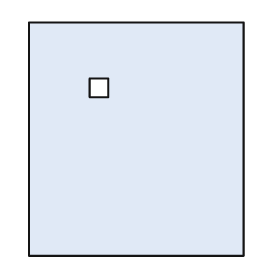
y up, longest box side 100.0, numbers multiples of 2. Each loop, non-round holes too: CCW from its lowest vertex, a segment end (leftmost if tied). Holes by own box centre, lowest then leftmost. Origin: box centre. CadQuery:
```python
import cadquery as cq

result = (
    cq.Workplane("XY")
    .moveTo(-46.0, -50.0)
    .lineTo(46.0, -50.0)
    .lineTo(46.0, 50.0)
    .lineTo(-46.0, 50.0)
    .close()
    .moveTo(-20.0, 18.0)
    .lineTo(-12.0, 18.0)
    .lineTo(-12.0, 26.0)
    .lineTo(-20.0, 26.0)
    .close()
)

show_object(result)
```